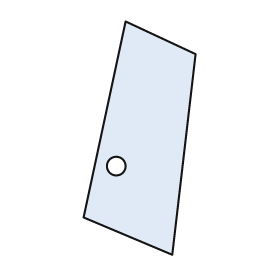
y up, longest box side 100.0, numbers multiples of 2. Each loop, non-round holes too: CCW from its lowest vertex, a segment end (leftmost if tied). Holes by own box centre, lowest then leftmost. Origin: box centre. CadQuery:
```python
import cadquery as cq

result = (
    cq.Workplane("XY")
    .moveTo(14.0, -50.0)
    .lineTo(24.0, 36.0)
    .lineTo(-6.0, 50.0)
    .lineTo(-24.0, -34.0)
    .close()
    .moveTo(-10.0, -12.0)
    .circle(4.0)
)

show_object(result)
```